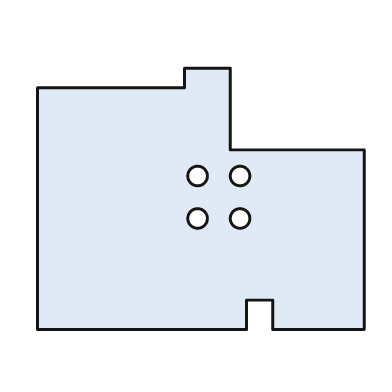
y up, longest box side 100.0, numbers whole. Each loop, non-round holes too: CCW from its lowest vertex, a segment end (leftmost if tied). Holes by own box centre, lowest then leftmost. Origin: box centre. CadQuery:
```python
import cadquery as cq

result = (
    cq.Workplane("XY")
    .moveTo(-50.0, -40.0)
    .lineTo(14.0, -40.0)
    .lineTo(14.0, -31.0)
    .lineTo(22.0, -31.0)
    .lineTo(22.0, -40.0)
    .lineTo(50.0, -40.0)
    .lineTo(50.0, 15.0)
    .lineTo(9.0, 15.0)
    .lineTo(9.0, 40.0)
    .lineTo(-5.0, 40.0)
    .lineTo(-5.0, 34.0)
    .lineTo(-50.0, 34.0)
    .close()
    .moveTo(-1.0, -6.0)
    .circle(3.0)
    .moveTo(12.0, -6.0)
    .circle(3.0)
    .moveTo(-1.0, 7.0)
    .circle(3.0)
    .moveTo(12.0, 7.0)
    .circle(3.0)
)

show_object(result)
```